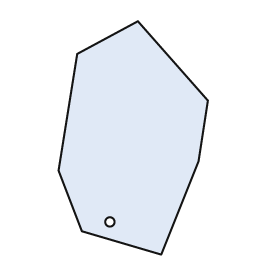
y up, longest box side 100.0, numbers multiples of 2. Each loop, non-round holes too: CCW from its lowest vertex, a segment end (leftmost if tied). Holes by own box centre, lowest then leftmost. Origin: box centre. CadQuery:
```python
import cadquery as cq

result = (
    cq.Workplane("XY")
    .moveTo(12.0, -50.0)
    .lineTo(28.0, -10.0)
    .lineTo(32.0, 16.0)
    .lineTo(2.0, 50.0)
    .lineTo(-24.0, 36.0)
    .lineTo(-32.0, -14.0)
    .lineTo(-22.0, -40.0)
    .close()
    .moveTo(-10.0, -36.0)
    .circle(2.0)
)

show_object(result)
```